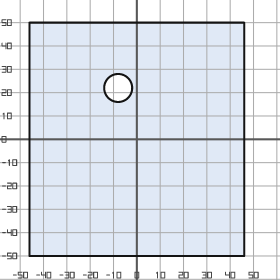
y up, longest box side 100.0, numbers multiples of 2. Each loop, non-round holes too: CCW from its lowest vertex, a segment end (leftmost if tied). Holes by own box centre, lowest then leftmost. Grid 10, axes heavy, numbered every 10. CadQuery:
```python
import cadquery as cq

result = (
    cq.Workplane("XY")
    .moveTo(-46.0, -50.0)
    .lineTo(46.0, -50.0)
    .lineTo(46.0, 50.0)
    .lineTo(-46.0, 50.0)
    .close()
    .moveTo(-8.0, 22.0)
    .circle(6.0)
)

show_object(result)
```